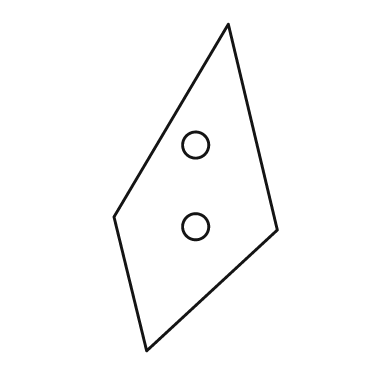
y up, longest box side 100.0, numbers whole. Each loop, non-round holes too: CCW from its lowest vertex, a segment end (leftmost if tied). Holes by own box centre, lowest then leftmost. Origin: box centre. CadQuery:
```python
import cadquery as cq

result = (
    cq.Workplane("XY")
    .moveTo(-15.0, -50.0)
    .lineTo(25.0, -13.0)
    .lineTo(10.0, 50.0)
    .lineTo(-25.0, -9.0)
    .close()
    .moveTo(0.0, -12.0)
    .circle(4.0)
    .moveTo(0.0, 13.0)
    .circle(4.0)
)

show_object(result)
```